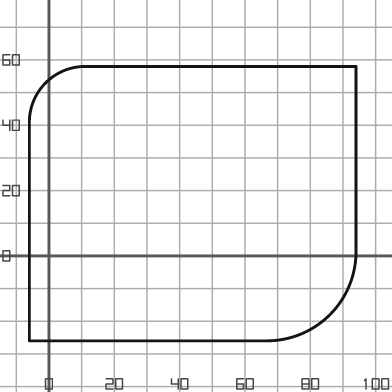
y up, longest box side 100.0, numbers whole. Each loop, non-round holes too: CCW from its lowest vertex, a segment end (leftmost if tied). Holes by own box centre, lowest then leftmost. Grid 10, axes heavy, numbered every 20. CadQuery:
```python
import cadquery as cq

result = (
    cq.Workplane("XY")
    .moveTo(-6.0, -26.0)
    .lineTo(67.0, -26.0)
    .threePointArc((86.0, -18.0), (94.0, 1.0))
    .lineTo(94.0, 58.0)
    .lineTo(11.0, 58.0)
    .threePointArc((-1.0, 53.0), (-6.0, 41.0))
    .close()
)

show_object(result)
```